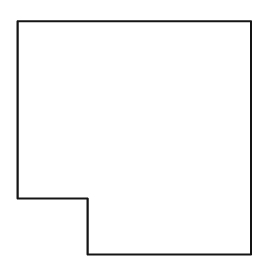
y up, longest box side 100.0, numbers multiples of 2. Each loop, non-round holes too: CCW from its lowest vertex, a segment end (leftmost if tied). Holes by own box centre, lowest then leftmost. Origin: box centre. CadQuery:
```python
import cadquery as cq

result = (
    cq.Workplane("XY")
    .moveTo(-20.0, -50.0)
    .lineTo(50.0, -50.0)
    .lineTo(50.0, 50.0)
    .lineTo(-50.0, 50.0)
    .lineTo(-50.0, -26.0)
    .lineTo(-20.0, -26.0)
    .close()
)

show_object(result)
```